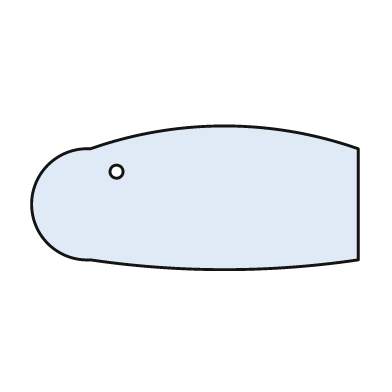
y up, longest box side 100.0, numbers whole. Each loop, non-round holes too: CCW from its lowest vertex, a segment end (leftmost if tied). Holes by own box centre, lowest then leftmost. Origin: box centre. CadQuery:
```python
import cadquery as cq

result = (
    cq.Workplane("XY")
    .moveTo(-32.0, -19.0)
    .threePointArc((9.0, -22.0), (50.0, -19.0))
    .lineTo(50.0, 15.0)
    .threePointArc((9.0, 22.0), (-32.0, 15.0))
    .threePointArc((-50.0, -2.0), (-32.0, -19.0))
    .close()
    .moveTo(-24.0, 8.0)
    .circle(2.0)
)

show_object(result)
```